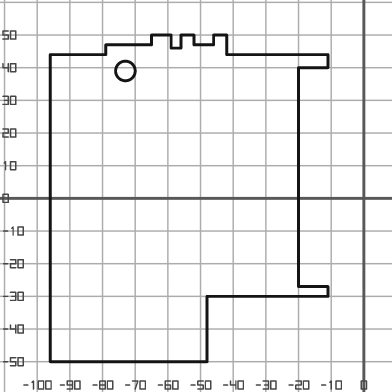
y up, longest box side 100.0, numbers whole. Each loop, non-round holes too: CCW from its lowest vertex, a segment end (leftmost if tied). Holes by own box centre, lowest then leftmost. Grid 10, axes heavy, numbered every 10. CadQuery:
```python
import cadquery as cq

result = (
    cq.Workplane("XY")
    .moveTo(-96.0, -50.0)
    .lineTo(-48.0, -50.0)
    .lineTo(-48.0, -30.0)
    .lineTo(-11.0, -30.0)
    .lineTo(-11.0, -27.0)
    .lineTo(-20.0, -27.0)
    .lineTo(-20.0, 40.0)
    .lineTo(-11.0, 40.0)
    .lineTo(-11.0, 44.0)
    .lineTo(-42.0, 44.0)
    .lineTo(-42.0, 50.0)
    .lineTo(-46.0, 50.0)
    .lineTo(-46.0, 47.0)
    .lineTo(-52.0, 47.0)
    .lineTo(-52.0, 50.0)
    .lineTo(-56.0, 50.0)
    .lineTo(-56.0, 46.0)
    .lineTo(-59.0, 46.0)
    .lineTo(-59.0, 50.0)
    .lineTo(-65.0, 50.0)
    .lineTo(-65.0, 47.0)
    .lineTo(-79.0, 47.0)
    .lineTo(-79.0, 44.0)
    .lineTo(-96.0, 44.0)
    .close()
    .moveTo(-73.0, 39.0)
    .circle(3.0)
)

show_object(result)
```